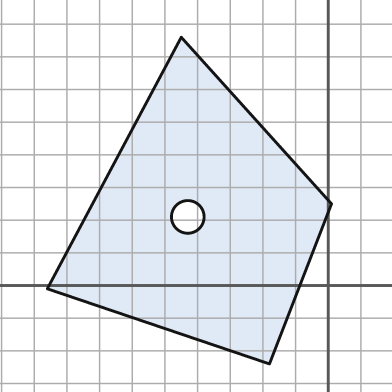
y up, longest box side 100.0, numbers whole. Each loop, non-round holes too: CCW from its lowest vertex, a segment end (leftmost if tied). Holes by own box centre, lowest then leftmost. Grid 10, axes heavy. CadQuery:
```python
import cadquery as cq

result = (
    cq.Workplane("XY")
    .moveTo(-18.0, -24.0)
    .lineTo(1.0, 25.0)
    .lineTo(-45.0, 76.0)
    .lineTo(-86.0, -1.0)
    .close()
    .moveTo(-43.0, 21.0)
    .circle(5.0)
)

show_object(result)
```